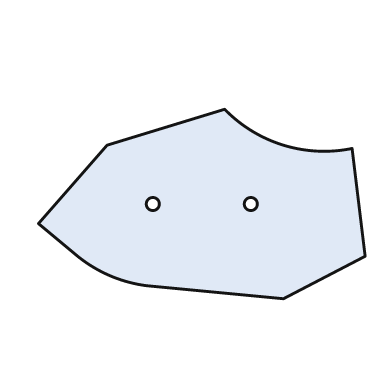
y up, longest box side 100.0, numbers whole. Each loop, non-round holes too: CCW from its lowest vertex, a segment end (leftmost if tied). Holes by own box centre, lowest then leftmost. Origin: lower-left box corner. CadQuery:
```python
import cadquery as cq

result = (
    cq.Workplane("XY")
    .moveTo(75.0, 0.0)
    .lineTo(100.0, 13.0)
    .lineTo(96.0, 46.0)
    .threePointArc((75.0, 47.0), (57.0, 58.0))
    .lineTo(21.0, 47.0)
    .lineTo(0.0, 23.0)
    .lineTo(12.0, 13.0)
    .threePointArc((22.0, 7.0), (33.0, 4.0))
    .close()
    .moveTo(35.0, 29.0)
    .circle(2.0)
    .moveTo(65.0, 29.0)
    .circle(2.0)
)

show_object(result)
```